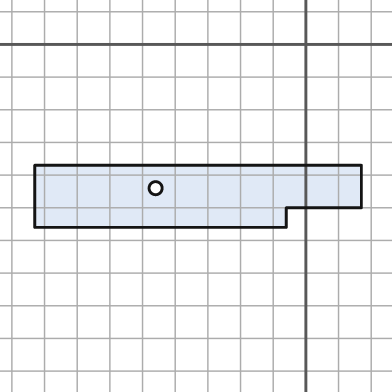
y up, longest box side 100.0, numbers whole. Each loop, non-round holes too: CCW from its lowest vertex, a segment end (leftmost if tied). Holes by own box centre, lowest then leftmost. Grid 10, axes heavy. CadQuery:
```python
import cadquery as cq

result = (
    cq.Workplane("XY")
    .moveTo(-83.0, -56.0)
    .lineTo(-6.0, -56.0)
    .lineTo(-6.0, -50.0)
    .lineTo(17.0, -50.0)
    .lineTo(17.0, -37.0)
    .lineTo(-83.0, -37.0)
    .close()
    .moveTo(-46.0, -44.0)
    .circle(2.0)
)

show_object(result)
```